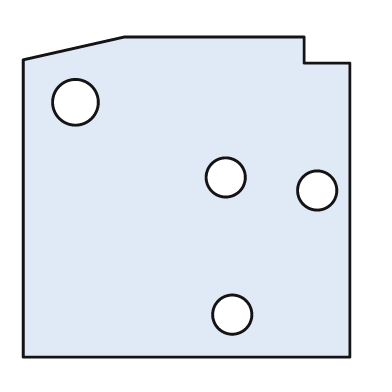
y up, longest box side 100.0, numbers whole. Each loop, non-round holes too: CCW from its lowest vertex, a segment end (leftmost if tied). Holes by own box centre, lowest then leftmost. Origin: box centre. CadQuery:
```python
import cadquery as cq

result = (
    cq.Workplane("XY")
    .moveTo(-50.0, -49.0)
    .lineTo(50.0, -49.0)
    .lineTo(50.0, 41.0)
    .lineTo(36.0, 41.0)
    .lineTo(36.0, 49.0)
    .lineTo(-19.0, 49.0)
    .lineTo(-50.0, 42.0)
    .close()
    .moveTo(14.0, -36.0)
    .circle(6.0)
    .moveTo(40.0, 2.0)
    .circle(6.0)
    .moveTo(12.0, 6.0)
    .circle(6.0)
    .moveTo(-34.0, 29.0)
    .circle(7.0)
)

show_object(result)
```